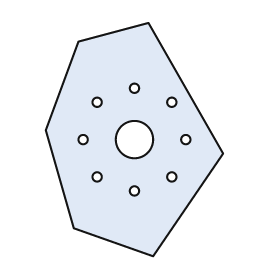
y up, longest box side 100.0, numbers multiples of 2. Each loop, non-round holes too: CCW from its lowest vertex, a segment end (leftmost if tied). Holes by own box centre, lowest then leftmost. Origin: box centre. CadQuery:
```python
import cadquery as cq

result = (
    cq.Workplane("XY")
    .moveTo(8.0, -50.0)
    .lineTo(38.0, -6.0)
    .lineTo(6.0, 50.0)
    .lineTo(-24.0, 42.0)
    .lineTo(-38.0, 4.0)
    .lineTo(-26.0, -38.0)
    .close()
    .moveTo(0.0, -22.0)
    .circle(2.0)
    .moveTo(-16.0, -16.0)
    .circle(2.0)
    .moveTo(16.0, -16.0)
    .circle(2.0)
    .moveTo(-22.0, 0.0)
    .circle(2.0)
    .moveTo(0.0, 0.0)
    .circle(8.0)
    .moveTo(22.0, 0.0)
    .circle(2.0)
    .moveTo(-16.0, 16.0)
    .circle(2.0)
    .moveTo(16.0, 16.0)
    .circle(2.0)
    .moveTo(0.0, 22.0)
    .circle(2.0)
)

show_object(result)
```